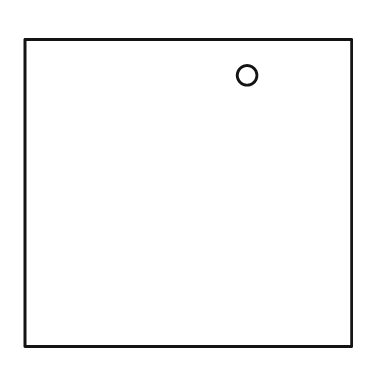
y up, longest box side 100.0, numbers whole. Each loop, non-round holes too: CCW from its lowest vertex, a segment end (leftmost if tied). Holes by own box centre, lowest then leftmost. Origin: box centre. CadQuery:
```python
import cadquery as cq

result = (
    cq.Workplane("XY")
    .moveTo(-50.0, -47.0)
    .lineTo(50.0, -47.0)
    .lineTo(50.0, 47.0)
    .lineTo(-50.0, 47.0)
    .close()
    .moveTo(18.0, 36.0)
    .circle(3.0)
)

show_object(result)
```